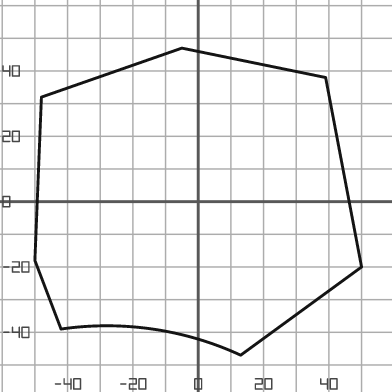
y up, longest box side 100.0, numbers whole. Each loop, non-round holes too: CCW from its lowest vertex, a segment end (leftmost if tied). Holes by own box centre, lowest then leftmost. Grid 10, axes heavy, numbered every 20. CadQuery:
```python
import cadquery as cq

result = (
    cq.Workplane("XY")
    .moveTo(13.0, -47.0)
    .lineTo(50.0, -20.0)
    .lineTo(39.0, 38.0)
    .lineTo(-5.0, 47.0)
    .lineTo(-48.0, 32.0)
    .lineTo(-50.0, -18.0)
    .lineTo(-42.0, -39.0)
    .threePointArc((-14.0, -39.0), (13.0, -47.0))
    .close()
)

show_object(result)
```